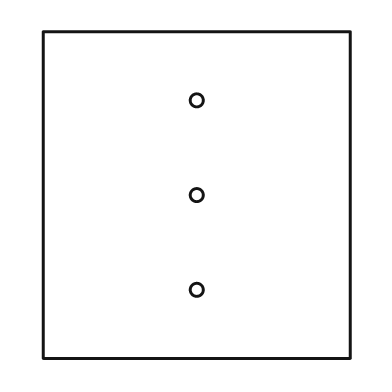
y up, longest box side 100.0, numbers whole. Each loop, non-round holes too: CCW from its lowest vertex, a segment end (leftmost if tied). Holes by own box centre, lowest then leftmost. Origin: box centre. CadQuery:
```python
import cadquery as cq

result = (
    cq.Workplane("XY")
    .moveTo(-47.0, -50.0)
    .lineTo(47.0, -50.0)
    .lineTo(47.0, 50.0)
    .lineTo(-47.0, 50.0)
    .close()
    .moveTo(0.0, -29.0)
    .circle(2.0)
    .moveTo(0.0, 0.0)
    .circle(2.0)
    .moveTo(0.0, 29.0)
    .circle(2.0)
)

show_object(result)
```